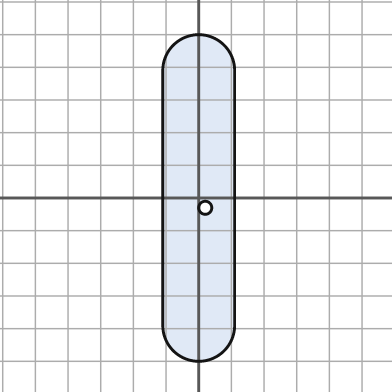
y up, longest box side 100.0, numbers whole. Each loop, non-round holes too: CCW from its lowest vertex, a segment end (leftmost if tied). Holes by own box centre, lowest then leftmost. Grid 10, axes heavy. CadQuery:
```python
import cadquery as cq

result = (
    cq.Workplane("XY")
    .moveTo(-11.0, -39.0)
    .threePointArc((0.0, -50.0), (11.0, -39.0))
    .lineTo(11.0, 39.0)
    .threePointArc((0.0, 50.0), (-11.0, 39.0))
    .close()
    .moveTo(2.0, -3.0)
    .circle(2.0)
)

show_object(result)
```